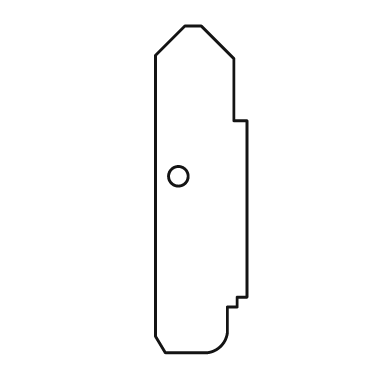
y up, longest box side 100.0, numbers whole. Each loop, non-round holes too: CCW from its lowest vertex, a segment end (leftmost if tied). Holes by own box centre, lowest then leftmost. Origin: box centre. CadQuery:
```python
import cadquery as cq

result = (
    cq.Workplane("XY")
    .moveTo(-11.0, -50.0)
    .lineTo(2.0, -50.0)
    .threePointArc((6.0, -48.0), (8.0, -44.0))
    .lineTo(8.0, -36.0)
    .lineTo(11.0, -36.0)
    .lineTo(11.0, -33.0)
    .lineTo(14.0, -33.0)
    .lineTo(14.0, 21.0)
    .lineTo(10.0, 21.0)
    .lineTo(10.0, 40.0)
    .lineTo(0.0, 50.0)
    .lineTo(-5.0, 50.0)
    .lineTo(-14.0, 41.0)
    .lineTo(-14.0, -45.0)
    .close()
    .moveTo(-7.0, 4.0)
    .circle(3.0)
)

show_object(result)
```